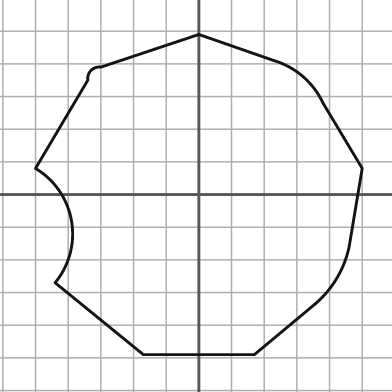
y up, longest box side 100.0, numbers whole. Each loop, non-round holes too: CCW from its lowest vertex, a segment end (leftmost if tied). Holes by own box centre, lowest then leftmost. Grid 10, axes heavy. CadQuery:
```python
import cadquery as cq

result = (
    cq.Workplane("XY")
    .moveTo(-17.0, -49.0)
    .lineTo(17.0, -49.0)
    .lineTo(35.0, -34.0)
    .threePointArc((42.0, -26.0), (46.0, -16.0))
    .lineTo(50.0, 8.0)
    .lineTo(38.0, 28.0)
    .threePointArc((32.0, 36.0), (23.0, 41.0))
    .lineTo(0.0, 49.0)
    .lineTo(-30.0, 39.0)
    .threePointArc((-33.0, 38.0), (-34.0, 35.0))
    .lineTo(-50.0, 8.0)
    .threePointArc((-39.0, -8.0), (-44.0, -27.0))
    .close()
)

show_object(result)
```